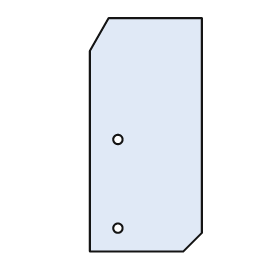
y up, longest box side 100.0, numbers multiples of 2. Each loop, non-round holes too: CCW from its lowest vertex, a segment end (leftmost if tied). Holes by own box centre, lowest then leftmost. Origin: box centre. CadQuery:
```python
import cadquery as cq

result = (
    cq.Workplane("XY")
    .moveTo(-24.0, -50.0)
    .lineTo(16.0, -50.0)
    .lineTo(24.0, -42.0)
    .lineTo(24.0, 50.0)
    .lineTo(-16.0, 50.0)
    .lineTo(-24.0, 36.0)
    .close()
    .moveTo(-12.0, -40.0)
    .circle(2.0)
    .moveTo(-12.0, -2.0)
    .circle(2.0)
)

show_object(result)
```